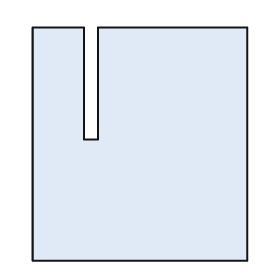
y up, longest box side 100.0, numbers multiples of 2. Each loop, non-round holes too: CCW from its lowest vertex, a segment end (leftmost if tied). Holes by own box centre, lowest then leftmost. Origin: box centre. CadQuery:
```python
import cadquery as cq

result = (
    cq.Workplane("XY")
    .moveTo(-46.0, -50.0)
    .lineTo(46.0, -50.0)
    .lineTo(46.0, 50.0)
    .lineTo(-18.0, 50.0)
    .lineTo(-18.0, 2.0)
    .lineTo(-24.0, 2.0)
    .lineTo(-24.0, 50.0)
    .lineTo(-46.0, 50.0)
    .close()
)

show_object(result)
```